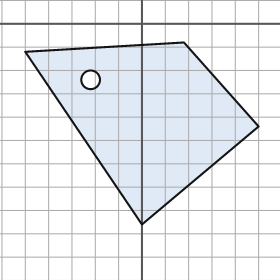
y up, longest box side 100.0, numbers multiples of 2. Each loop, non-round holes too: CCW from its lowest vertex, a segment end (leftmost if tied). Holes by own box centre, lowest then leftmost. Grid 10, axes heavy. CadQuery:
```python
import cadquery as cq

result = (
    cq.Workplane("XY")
    .moveTo(0.0, -86.0)
    .lineTo(50.0, -44.0)
    .lineTo(18.0, -8.0)
    .lineTo(-50.0, -12.0)
    .close()
    .moveTo(-22.0, -24.0)
    .circle(4.0)
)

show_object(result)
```